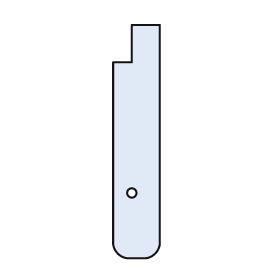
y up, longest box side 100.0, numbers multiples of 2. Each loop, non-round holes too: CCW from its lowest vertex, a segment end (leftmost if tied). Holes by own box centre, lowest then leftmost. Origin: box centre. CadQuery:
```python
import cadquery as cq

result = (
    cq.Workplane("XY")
    .moveTo(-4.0, -50.0)
    .lineTo(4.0, -50.0)
    .threePointArc((8.0, -48.0), (10.0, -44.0))
    .lineTo(10.0, 50.0)
    .lineTo(-2.0, 50.0)
    .lineTo(-2.0, 34.0)
    .lineTo(-10.0, 34.0)
    .lineTo(-10.0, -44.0)
    .threePointArc((-8.0, -48.0), (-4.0, -50.0))
    .close()
    .moveTo(-2.0, -22.0)
    .circle(2.0)
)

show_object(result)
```